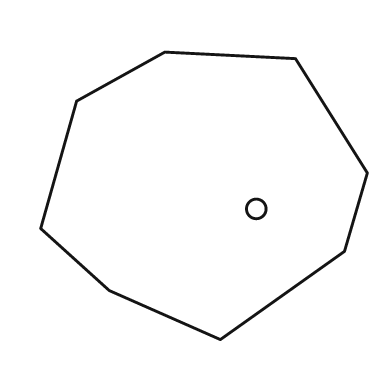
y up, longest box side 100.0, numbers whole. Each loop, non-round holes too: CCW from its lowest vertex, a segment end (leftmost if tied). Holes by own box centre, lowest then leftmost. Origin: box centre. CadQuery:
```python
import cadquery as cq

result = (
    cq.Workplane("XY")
    .moveTo(5.0, -44.0)
    .lineTo(43.0, -17.0)
    .lineTo(50.0, 7.0)
    .lineTo(28.0, 42.0)
    .lineTo(-12.0, 44.0)
    .lineTo(-39.0, 29.0)
    .lineTo(-50.0, -10.0)
    .lineTo(-29.0, -29.0)
    .close()
    .moveTo(16.0, -4.0)
    .circle(3.0)
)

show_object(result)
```